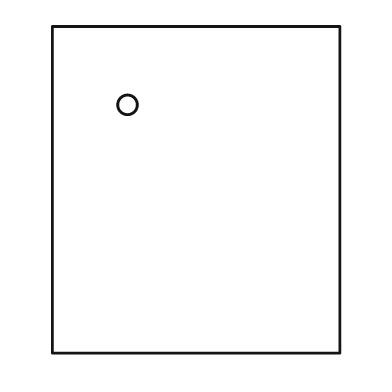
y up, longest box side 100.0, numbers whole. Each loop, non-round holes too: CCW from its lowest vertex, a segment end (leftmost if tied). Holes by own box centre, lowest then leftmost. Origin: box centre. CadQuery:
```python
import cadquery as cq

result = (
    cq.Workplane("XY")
    .moveTo(-44.0, -50.0)
    .lineTo(44.0, -50.0)
    .lineTo(44.0, 50.0)
    .lineTo(-44.0, 50.0)
    .close()
    .moveTo(-21.0, 26.0)
    .circle(3.0)
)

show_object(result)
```